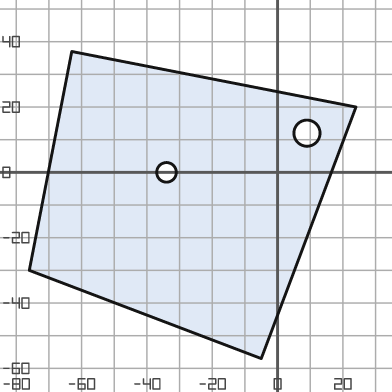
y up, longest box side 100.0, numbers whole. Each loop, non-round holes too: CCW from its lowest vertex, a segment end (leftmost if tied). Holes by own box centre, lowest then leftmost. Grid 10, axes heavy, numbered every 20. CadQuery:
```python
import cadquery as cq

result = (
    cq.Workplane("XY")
    .moveTo(-5.0, -57.0)
    .lineTo(24.0, 20.0)
    .lineTo(-63.0, 37.0)
    .lineTo(-76.0, -30.0)
    .close()
    .moveTo(-34.0, 0.0)
    .circle(3.0)
    .moveTo(9.0, 12.0)
    .circle(4.0)
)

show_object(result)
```